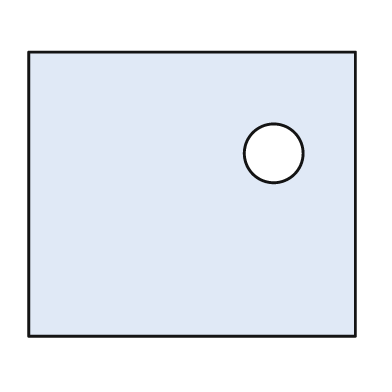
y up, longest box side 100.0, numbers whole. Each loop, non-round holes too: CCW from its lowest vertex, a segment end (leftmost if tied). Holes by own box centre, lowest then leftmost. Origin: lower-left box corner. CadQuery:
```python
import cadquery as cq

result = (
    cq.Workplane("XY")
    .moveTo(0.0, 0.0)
    .lineTo(100.0, 0.0)
    .lineTo(100.0, 87.0)
    .lineTo(0.0, 87.0)
    .close()
    .moveTo(75.0, 56.0)
    .circle(9.0)
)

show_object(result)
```